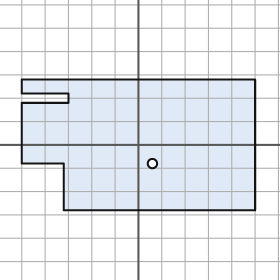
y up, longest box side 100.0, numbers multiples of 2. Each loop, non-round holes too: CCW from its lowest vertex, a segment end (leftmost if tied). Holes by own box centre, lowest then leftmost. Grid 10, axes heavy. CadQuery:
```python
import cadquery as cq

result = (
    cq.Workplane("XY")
    .moveTo(-32.0, -28.0)
    .lineTo(50.0, -28.0)
    .lineTo(50.0, 28.0)
    .lineTo(-50.0, 28.0)
    .lineTo(-50.0, 22.0)
    .lineTo(-30.0, 22.0)
    .lineTo(-30.0, 18.0)
    .lineTo(-50.0, 18.0)
    .lineTo(-50.0, -8.0)
    .lineTo(-32.0, -8.0)
    .close()
    .moveTo(6.0, -8.0)
    .circle(2.0)
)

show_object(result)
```